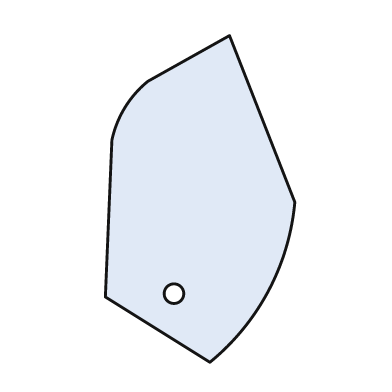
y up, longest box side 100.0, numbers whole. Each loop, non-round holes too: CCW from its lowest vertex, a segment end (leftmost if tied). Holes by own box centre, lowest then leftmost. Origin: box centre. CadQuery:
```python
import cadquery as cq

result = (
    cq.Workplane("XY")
    .moveTo(3.0, -50.0)
    .threePointArc((21.0, -28.0), (29.0, -1.0))
    .lineTo(9.0, 50.0)
    .lineTo(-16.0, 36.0)
    .threePointArc((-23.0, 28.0), (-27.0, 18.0))
    .lineTo(-29.0, -30.0)
    .close()
    .moveTo(-8.0, -29.0)
    .circle(3.0)
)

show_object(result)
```